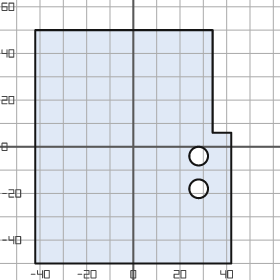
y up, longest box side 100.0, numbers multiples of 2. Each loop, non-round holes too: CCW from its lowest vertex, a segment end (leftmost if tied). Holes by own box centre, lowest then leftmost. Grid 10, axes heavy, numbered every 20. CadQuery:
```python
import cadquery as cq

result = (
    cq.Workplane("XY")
    .moveTo(-42.0, -50.0)
    .lineTo(42.0, -50.0)
    .lineTo(42.0, 6.0)
    .lineTo(34.0, 6.0)
    .lineTo(34.0, 50.0)
    .lineTo(-42.0, 50.0)
    .close()
    .moveTo(28.0, -18.0)
    .circle(4.0)
    .moveTo(28.0, -4.0)
    .circle(4.0)
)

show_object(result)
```